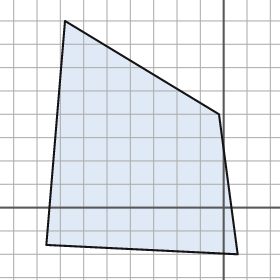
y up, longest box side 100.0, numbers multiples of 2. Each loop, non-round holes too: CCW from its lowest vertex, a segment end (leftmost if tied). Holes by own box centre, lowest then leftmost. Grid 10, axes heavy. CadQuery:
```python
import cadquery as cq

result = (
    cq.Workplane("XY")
    .moveTo(6.0, -20.0)
    .lineTo(-2.0, 40.0)
    .lineTo(-68.0, 80.0)
    .lineTo(-76.0, -16.0)
    .close()
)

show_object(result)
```